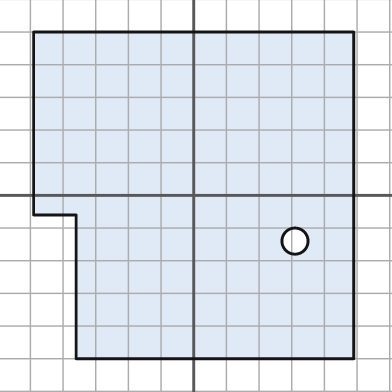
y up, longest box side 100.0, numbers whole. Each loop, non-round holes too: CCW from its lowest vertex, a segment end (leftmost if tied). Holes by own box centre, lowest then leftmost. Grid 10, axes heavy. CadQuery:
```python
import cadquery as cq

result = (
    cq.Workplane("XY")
    .moveTo(-36.0, -50.0)
    .lineTo(49.0, -50.0)
    .lineTo(49.0, 50.0)
    .lineTo(-49.0, 50.0)
    .lineTo(-49.0, -6.0)
    .lineTo(-36.0, -6.0)
    .close()
    .moveTo(31.0, -14.0)
    .circle(4.0)
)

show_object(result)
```